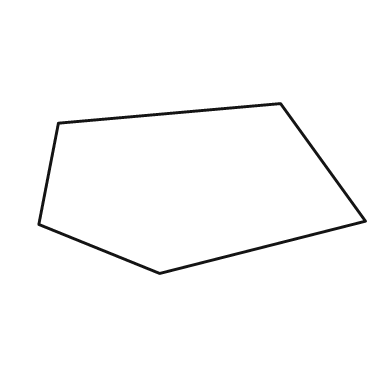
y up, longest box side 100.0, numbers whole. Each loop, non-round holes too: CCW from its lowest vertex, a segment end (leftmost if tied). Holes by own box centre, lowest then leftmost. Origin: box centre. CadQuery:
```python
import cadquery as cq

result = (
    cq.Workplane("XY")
    .moveTo(-13.0, -26.0)
    .lineTo(50.0, -10.0)
    .lineTo(24.0, 26.0)
    .lineTo(-44.0, 20.0)
    .lineTo(-50.0, -11.0)
    .close()
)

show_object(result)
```